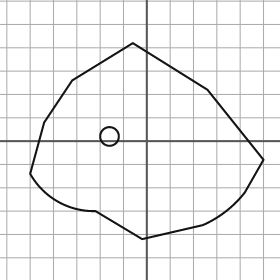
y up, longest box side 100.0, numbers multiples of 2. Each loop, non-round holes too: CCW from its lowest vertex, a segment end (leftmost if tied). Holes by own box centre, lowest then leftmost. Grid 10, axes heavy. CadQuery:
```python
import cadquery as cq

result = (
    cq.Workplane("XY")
    .moveTo(-2.0, -42.0)
    .lineTo(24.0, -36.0)
    .threePointArc((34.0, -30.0), (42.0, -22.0))
    .lineTo(50.0, -8.0)
    .lineTo(26.0, 22.0)
    .lineTo(-6.0, 42.0)
    .lineTo(-32.0, 26.0)
    .lineTo(-44.0, 8.0)
    .lineTo(-50.0, -14.0)
    .threePointArc((-38.0, -26.0), (-22.0, -30.0))
    .close()
    .moveTo(-16.0, 2.0)
    .circle(4.0)
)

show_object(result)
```